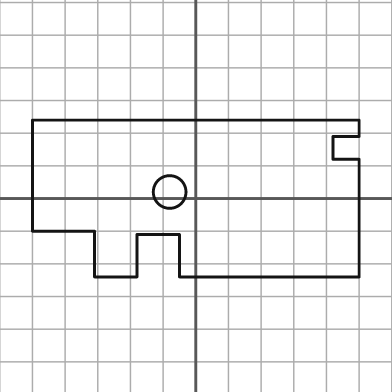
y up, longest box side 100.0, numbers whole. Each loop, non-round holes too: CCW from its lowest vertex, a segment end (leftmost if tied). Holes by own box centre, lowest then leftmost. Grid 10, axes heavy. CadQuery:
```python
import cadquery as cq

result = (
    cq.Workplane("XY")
    .moveTo(-31.0, -24.0)
    .lineTo(-18.0, -24.0)
    .lineTo(-18.0, -11.0)
    .lineTo(-5.0, -11.0)
    .lineTo(-5.0, -24.0)
    .lineTo(50.0, -24.0)
    .lineTo(50.0, 12.0)
    .lineTo(42.0, 12.0)
    .lineTo(42.0, 19.0)
    .lineTo(50.0, 19.0)
    .lineTo(50.0, 24.0)
    .lineTo(-50.0, 24.0)
    .lineTo(-50.0, -10.0)
    .lineTo(-31.0, -10.0)
    .close()
    .moveTo(-8.0, 2.0)
    .circle(5.0)
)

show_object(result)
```